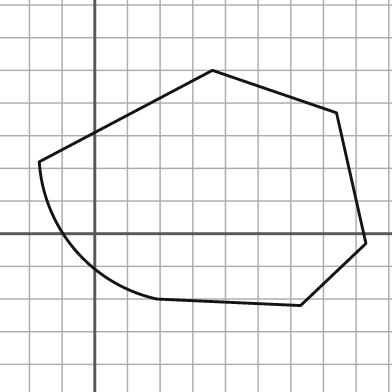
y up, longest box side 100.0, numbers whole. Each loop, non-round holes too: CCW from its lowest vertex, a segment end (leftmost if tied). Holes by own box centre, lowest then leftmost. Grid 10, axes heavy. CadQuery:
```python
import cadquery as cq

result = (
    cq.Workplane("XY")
    .moveTo(63.0, -22.0)
    .lineTo(83.0, -3.0)
    .lineTo(74.0, 37.0)
    .lineTo(36.0, 50.0)
    .lineTo(-17.0, 22.0)
    .threePointArc((-6.0, -5.0), (19.0, -20.0))
    .close()
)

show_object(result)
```